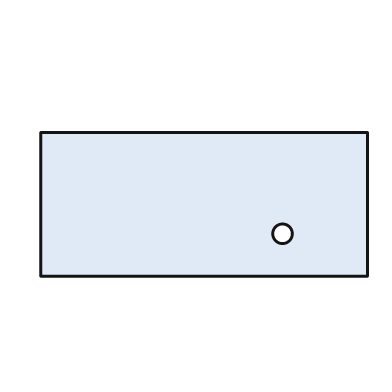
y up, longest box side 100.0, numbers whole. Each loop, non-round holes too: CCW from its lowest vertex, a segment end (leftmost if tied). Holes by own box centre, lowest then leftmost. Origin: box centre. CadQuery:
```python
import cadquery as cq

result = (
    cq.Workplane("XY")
    .moveTo(-50.0, -22.0)
    .lineTo(50.0, -22.0)
    .lineTo(50.0, 22.0)
    .lineTo(-50.0, 22.0)
    .close()
    .moveTo(24.0, -9.0)
    .circle(3.0)
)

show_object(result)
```